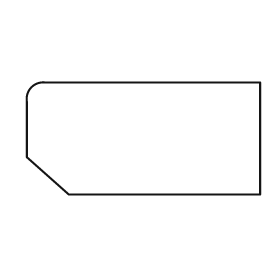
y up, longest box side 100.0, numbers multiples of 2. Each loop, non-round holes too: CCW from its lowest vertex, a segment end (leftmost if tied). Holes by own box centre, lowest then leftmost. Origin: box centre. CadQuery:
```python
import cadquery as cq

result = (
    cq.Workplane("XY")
    .moveTo(-32.0, -24.0)
    .lineTo(50.0, -24.0)
    .lineTo(50.0, 24.0)
    .lineTo(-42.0, 24.0)
    .threePointArc((-48.0, 22.0), (-50.0, 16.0))
    .lineTo(-50.0, -8.0)
    .close()
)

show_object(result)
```